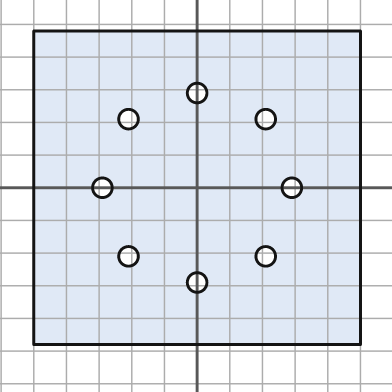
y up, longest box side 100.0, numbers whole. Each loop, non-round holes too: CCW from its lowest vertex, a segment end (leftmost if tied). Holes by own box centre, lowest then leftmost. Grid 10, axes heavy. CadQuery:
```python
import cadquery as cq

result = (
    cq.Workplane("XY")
    .moveTo(-50.0, -48.0)
    .lineTo(50.0, -48.0)
    .lineTo(50.0, 48.0)
    .lineTo(-50.0, 48.0)
    .close()
    .moveTo(0.0, -29.0)
    .circle(3.0)
    .moveTo(-21.0, -21.0)
    .circle(3.0)
    .moveTo(21.0, -21.0)
    .circle(3.0)
    .moveTo(-29.0, 0.0)
    .circle(3.0)
    .moveTo(29.0, 0.0)
    .circle(3.0)
    .moveTo(-21.0, 21.0)
    .circle(3.0)
    .moveTo(21.0, 21.0)
    .circle(3.0)
    .moveTo(0.0, 29.0)
    .circle(3.0)
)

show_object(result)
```